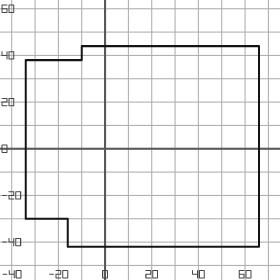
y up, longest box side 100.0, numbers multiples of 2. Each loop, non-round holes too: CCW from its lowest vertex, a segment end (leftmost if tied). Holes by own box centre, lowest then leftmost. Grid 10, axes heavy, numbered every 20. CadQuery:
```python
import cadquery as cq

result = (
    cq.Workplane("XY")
    .moveTo(-16.0, -42.0)
    .lineTo(66.0, -42.0)
    .lineTo(66.0, 44.0)
    .lineTo(-10.0, 44.0)
    .lineTo(-10.0, 38.0)
    .lineTo(-34.0, 38.0)
    .lineTo(-34.0, -30.0)
    .lineTo(-16.0, -30.0)
    .close()
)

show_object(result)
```